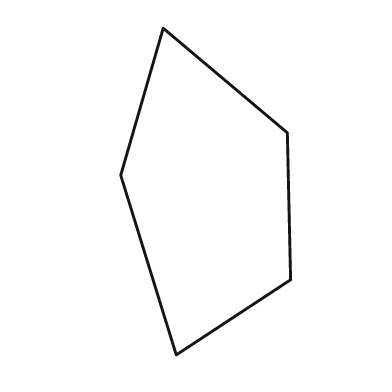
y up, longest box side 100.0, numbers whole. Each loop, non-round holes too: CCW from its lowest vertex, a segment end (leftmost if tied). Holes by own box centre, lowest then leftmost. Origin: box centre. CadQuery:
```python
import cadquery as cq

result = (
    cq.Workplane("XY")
    .moveTo(-9.0, -50.0)
    .lineTo(26.0, -27.0)
    .lineTo(25.0, 18.0)
    .lineTo(-13.0, 50.0)
    .lineTo(-26.0, 5.0)
    .close()
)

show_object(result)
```